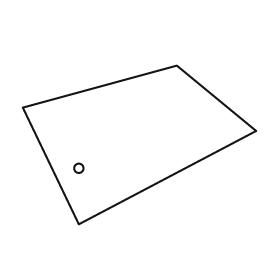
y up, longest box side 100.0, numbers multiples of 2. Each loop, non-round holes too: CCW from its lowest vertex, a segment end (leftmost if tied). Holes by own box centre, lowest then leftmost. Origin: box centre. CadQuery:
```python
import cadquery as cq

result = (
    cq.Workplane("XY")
    .moveTo(-26.0, -34.0)
    .lineTo(50.0, 6.0)
    .lineTo(16.0, 34.0)
    .lineTo(-50.0, 16.0)
    .close()
    .moveTo(-26.0, -10.0)
    .circle(2.0)
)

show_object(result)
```